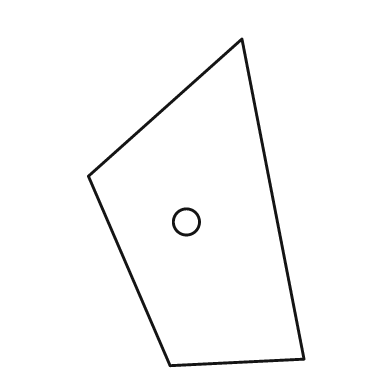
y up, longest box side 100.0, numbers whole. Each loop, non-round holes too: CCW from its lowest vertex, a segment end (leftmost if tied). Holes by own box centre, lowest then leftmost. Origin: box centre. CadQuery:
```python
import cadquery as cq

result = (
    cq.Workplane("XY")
    .moveTo(-8.0, -50.0)
    .lineTo(33.0, -48.0)
    .lineTo(14.0, 50.0)
    .lineTo(-33.0, 8.0)
    .close()
    .moveTo(-3.0, -6.0)
    .circle(4.0)
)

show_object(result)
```